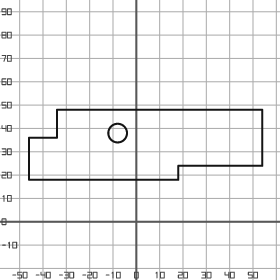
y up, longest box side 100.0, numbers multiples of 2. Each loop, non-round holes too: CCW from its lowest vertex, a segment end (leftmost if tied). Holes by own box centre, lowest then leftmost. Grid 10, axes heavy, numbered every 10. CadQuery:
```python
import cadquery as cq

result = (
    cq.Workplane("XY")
    .moveTo(-46.0, 18.0)
    .lineTo(18.0, 18.0)
    .lineTo(18.0, 24.0)
    .lineTo(54.0, 24.0)
    .lineTo(54.0, 48.0)
    .lineTo(-34.0, 48.0)
    .lineTo(-34.0, 36.0)
    .lineTo(-46.0, 36.0)
    .close()
    .moveTo(-8.0, 38.0)
    .circle(4.0)
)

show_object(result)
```